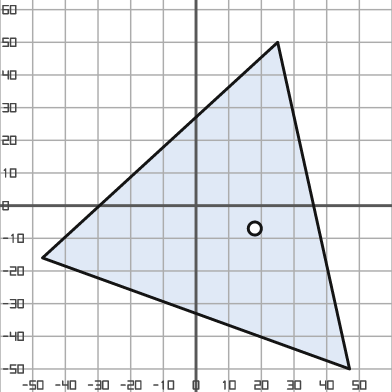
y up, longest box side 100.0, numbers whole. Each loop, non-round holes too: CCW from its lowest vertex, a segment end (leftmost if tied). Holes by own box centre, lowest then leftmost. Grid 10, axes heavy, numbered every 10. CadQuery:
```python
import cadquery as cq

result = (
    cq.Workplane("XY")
    .moveTo(47.0, -50.0)
    .lineTo(25.0, 50.0)
    .lineTo(-47.0, -16.0)
    .close()
    .moveTo(18.0, -7.0)
    .circle(2.0)
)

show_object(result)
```